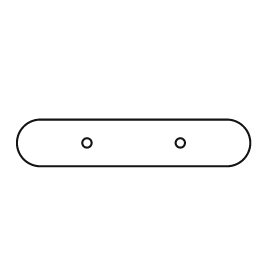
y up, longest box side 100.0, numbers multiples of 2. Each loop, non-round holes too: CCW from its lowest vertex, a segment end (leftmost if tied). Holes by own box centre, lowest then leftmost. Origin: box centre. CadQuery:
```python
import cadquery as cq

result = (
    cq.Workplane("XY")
    .moveTo(-40.0, -10.0)
    .lineTo(40.0, -10.0)
    .threePointArc((50.0, 0.0), (40.0, 10.0))
    .lineTo(-40.0, 10.0)
    .threePointArc((-50.0, 0.0), (-40.0, -10.0))
    .close()
    .moveTo(-20.0, 0.0)
    .circle(2.0)
    .moveTo(20.0, 0.0)
    .circle(2.0)
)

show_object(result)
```